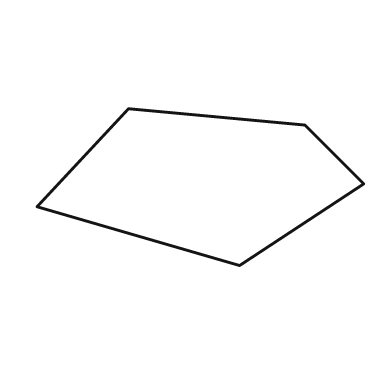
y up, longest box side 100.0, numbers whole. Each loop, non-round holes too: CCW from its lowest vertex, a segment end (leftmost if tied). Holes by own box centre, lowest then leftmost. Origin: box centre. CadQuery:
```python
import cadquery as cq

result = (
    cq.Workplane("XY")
    .moveTo(12.0, -24.0)
    .lineTo(50.0, 1.0)
    .lineTo(32.0, 19.0)
    .lineTo(-22.0, 24.0)
    .lineTo(-50.0, -6.0)
    .close()
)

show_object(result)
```